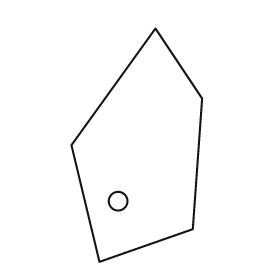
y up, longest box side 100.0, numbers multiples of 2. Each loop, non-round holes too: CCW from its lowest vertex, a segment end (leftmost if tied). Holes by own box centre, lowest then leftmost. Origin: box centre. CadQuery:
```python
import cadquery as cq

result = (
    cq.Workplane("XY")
    .moveTo(-16.0, -50.0)
    .lineTo(24.0, -36.0)
    .lineTo(28.0, 20.0)
    .lineTo(8.0, 50.0)
    .lineTo(-28.0, 0.0)
    .close()
    .moveTo(-8.0, -24.0)
    .circle(4.0)
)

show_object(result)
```